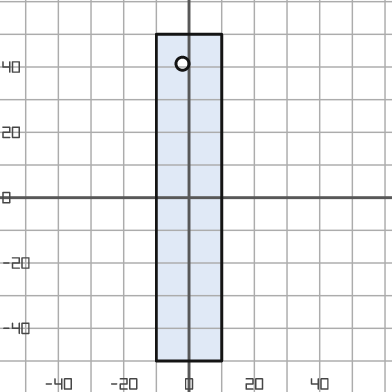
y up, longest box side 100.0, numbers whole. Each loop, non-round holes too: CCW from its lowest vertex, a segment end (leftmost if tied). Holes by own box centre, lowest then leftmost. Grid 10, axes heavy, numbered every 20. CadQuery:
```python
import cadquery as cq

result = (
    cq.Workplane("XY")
    .moveTo(-10.0, -50.0)
    .lineTo(10.0, -50.0)
    .lineTo(10.0, 50.0)
    .lineTo(-10.0, 50.0)
    .close()
    .moveTo(-2.0, 41.0)
    .circle(2.0)
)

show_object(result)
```